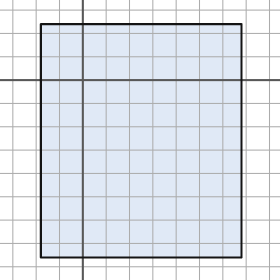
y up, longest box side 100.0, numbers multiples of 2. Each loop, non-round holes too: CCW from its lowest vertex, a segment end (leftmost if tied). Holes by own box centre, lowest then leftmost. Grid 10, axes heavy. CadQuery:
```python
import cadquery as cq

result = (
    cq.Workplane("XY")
    .moveTo(-18.0, -76.0)
    .lineTo(68.0, -76.0)
    .lineTo(68.0, 24.0)
    .lineTo(-18.0, 24.0)
    .close()
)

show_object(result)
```